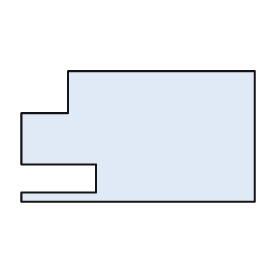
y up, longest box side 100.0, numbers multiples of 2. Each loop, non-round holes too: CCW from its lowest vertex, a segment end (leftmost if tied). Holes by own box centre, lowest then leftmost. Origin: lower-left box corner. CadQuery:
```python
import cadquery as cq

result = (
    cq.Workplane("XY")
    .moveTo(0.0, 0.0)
    .lineTo(100.0, 0.0)
    .lineTo(100.0, 56.0)
    .lineTo(20.0, 56.0)
    .lineTo(20.0, 38.0)
    .lineTo(0.0, 38.0)
    .lineTo(0.0, 16.0)
    .lineTo(32.0, 16.0)
    .lineTo(32.0, 4.0)
    .lineTo(0.0, 4.0)
    .close()
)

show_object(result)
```